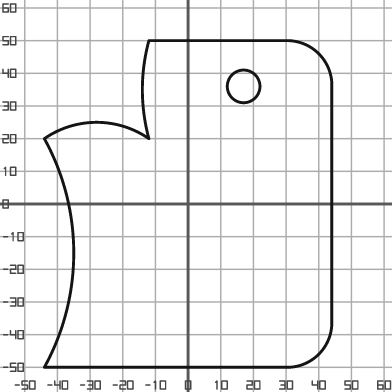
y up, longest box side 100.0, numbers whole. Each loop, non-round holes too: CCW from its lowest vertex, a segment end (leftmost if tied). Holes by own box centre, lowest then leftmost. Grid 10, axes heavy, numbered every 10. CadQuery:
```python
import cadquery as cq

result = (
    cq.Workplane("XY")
    .moveTo(-44.0, -50.0)
    .lineTo(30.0, -50.0)
    .threePointArc((40.0, -46.0), (44.0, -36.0))
    .lineTo(44.0, 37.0)
    .threePointArc((40.0, 46.0), (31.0, 50.0))
    .lineTo(-12.0, 50.0)
    .threePointArc((-14.0, 35.0), (-12.0, 20.0))
    .threePointArc((-28.0, 25.0), (-44.0, 20.0))
    .threePointArc((-35.0, -15.0), (-44.0, -50.0))
    .close()
    .moveTo(17.0, 36.0)
    .circle(5.0)
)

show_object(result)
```